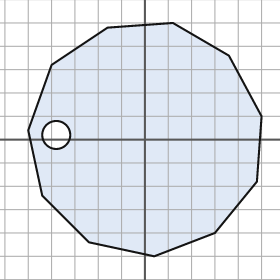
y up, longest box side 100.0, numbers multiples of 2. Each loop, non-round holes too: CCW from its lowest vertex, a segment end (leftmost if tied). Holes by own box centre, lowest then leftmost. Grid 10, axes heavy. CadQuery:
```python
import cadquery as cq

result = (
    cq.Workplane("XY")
    .moveTo(4.0, -50.0)
    .lineTo(30.0, -40.0)
    .lineTo(48.0, -18.0)
    .lineTo(50.0, 10.0)
    .lineTo(36.0, 36.0)
    .lineTo(12.0, 50.0)
    .lineTo(-16.0, 48.0)
    .lineTo(-40.0, 32.0)
    .lineTo(-50.0, 4.0)
    .lineTo(-44.0, -24.0)
    .lineTo(-24.0, -44.0)
    .close()
    .moveTo(-38.0, 2.0)
    .circle(6.0)
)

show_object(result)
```